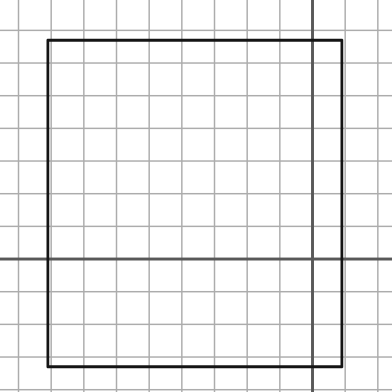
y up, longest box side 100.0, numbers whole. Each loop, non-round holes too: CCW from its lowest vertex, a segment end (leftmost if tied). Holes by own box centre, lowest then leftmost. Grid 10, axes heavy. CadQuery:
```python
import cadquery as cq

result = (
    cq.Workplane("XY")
    .moveTo(-81.0, -33.0)
    .lineTo(9.0, -33.0)
    .lineTo(9.0, 67.0)
    .lineTo(-81.0, 67.0)
    .close()
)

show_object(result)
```